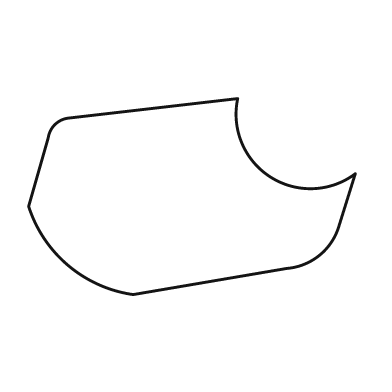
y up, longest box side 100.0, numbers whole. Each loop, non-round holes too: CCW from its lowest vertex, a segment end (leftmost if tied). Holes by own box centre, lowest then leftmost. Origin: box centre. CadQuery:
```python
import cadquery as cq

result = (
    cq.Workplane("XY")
    .moveTo(-18.0, -30.0)
    .lineTo(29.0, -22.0)
    .threePointArc((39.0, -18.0), (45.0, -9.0))
    .lineTo(50.0, 7.0)
    .threePointArc((24.0, 6.0), (14.0, 30.0))
    .lineTo(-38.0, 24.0)
    .threePointArc((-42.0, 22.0), (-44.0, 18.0))
    .lineTo(-50.0, -3.0)
    .threePointArc((-38.0, -21.0), (-18.0, -30.0))
    .close()
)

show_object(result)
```